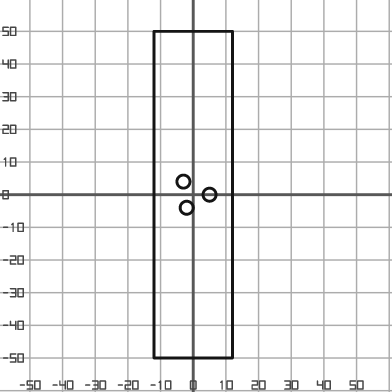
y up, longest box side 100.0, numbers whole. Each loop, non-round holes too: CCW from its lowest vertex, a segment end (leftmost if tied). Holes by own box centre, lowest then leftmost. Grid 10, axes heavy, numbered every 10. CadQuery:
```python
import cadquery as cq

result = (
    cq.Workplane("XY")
    .moveTo(-12.0, -50.0)
    .lineTo(12.0, -50.0)
    .lineTo(12.0, 50.0)
    .lineTo(-12.0, 50.0)
    .close()
    .moveTo(-2.0, -4.0)
    .circle(2.0)
    .moveTo(5.0, 0.0)
    .circle(2.0)
    .moveTo(-3.0, 4.0)
    .circle(2.0)
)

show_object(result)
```